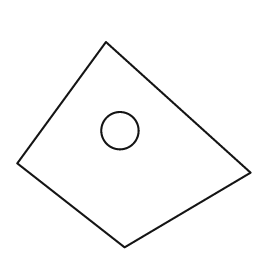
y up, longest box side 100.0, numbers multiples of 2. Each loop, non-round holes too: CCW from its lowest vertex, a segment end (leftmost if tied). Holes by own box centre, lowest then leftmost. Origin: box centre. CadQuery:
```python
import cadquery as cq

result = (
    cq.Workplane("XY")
    .moveTo(-4.0, -44.0)
    .lineTo(50.0, -12.0)
    .lineTo(-12.0, 44.0)
    .lineTo(-50.0, -8.0)
    .close()
    .moveTo(-6.0, 6.0)
    .circle(8.0)
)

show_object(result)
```